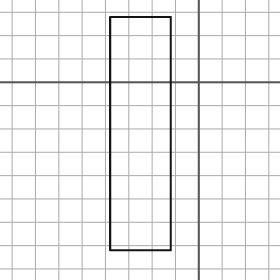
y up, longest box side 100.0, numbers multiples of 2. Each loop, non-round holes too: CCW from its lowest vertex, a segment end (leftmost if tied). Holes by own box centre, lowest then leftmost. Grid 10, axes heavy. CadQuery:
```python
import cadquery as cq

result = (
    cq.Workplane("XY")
    .moveTo(-38.0, -72.0)
    .lineTo(-12.0, -72.0)
    .lineTo(-12.0, 28.0)
    .lineTo(-38.0, 28.0)
    .close()
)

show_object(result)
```